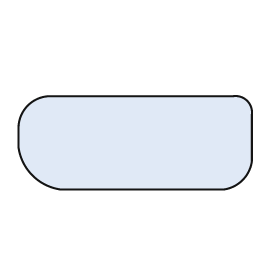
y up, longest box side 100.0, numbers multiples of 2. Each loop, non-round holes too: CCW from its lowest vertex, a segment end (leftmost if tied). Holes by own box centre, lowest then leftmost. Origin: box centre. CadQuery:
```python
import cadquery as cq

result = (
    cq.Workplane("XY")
    .moveTo(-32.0, -20.0)
    .lineTo(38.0, -20.0)
    .threePointArc((46.0, -16.0), (50.0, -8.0))
    .lineTo(50.0, 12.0)
    .threePointArc((48.0, 18.0), (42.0, 20.0))
    .lineTo(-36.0, 20.0)
    .threePointArc((-46.0, 16.0), (-50.0, 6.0))
    .lineTo(-50.0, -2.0)
    .threePointArc((-44.0, -14.0), (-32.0, -20.0))
    .close()
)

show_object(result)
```